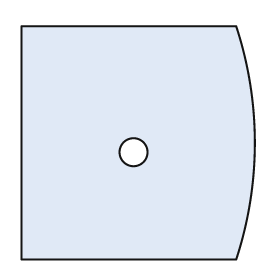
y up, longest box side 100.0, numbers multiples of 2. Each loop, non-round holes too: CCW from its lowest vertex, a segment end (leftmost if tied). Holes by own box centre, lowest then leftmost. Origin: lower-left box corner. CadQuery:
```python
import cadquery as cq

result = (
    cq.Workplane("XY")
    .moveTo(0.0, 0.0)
    .lineTo(92.0, 0.0)
    .threePointArc((100.0, 50.0), (92.0, 100.0))
    .lineTo(0.0, 100.0)
    .close()
    .moveTo(48.0, 46.0)
    .circle(6.0)
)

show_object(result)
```